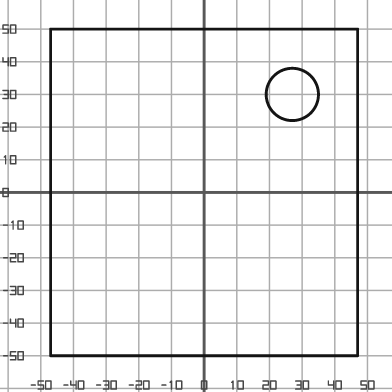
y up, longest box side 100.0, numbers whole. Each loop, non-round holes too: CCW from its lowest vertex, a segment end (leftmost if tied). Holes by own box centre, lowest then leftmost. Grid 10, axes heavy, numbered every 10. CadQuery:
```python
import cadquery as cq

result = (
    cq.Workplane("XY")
    .moveTo(-47.0, -50.0)
    .lineTo(47.0, -50.0)
    .lineTo(47.0, 50.0)
    .lineTo(-47.0, 50.0)
    .close()
    .moveTo(27.0, 30.0)
    .circle(8.0)
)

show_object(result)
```